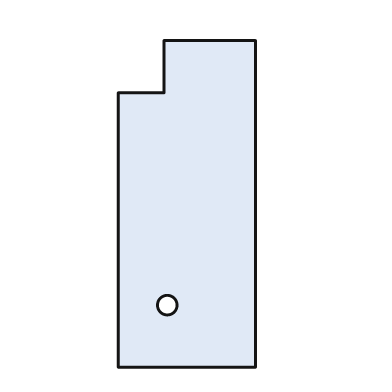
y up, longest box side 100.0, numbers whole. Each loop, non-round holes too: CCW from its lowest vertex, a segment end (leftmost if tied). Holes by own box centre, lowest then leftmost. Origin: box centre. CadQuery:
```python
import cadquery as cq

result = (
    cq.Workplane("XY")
    .moveTo(-21.0, -50.0)
    .lineTo(21.0, -50.0)
    .lineTo(21.0, 50.0)
    .lineTo(-7.0, 50.0)
    .lineTo(-7.0, 34.0)
    .lineTo(-21.0, 34.0)
    .close()
    .moveTo(-6.0, -31.0)
    .circle(3.0)
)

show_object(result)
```